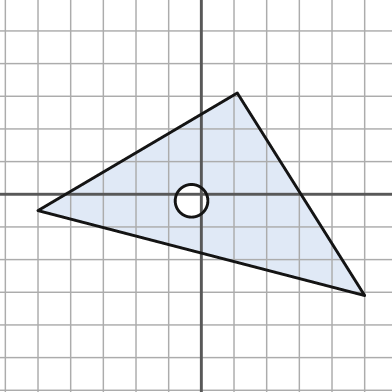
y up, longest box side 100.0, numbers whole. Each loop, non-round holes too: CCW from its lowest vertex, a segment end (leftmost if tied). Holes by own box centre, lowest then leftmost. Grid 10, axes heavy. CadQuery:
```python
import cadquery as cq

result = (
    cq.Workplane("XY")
    .moveTo(50.0, -31.0)
    .lineTo(11.0, 31.0)
    .lineTo(-50.0, -5.0)
    .close()
    .moveTo(-3.0, -2.0)
    .circle(5.0)
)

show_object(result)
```